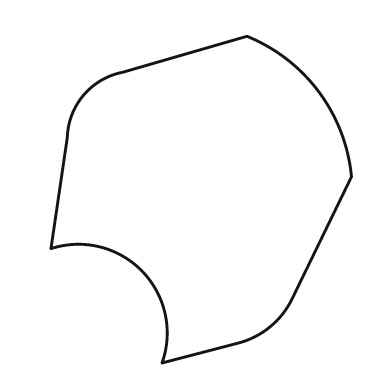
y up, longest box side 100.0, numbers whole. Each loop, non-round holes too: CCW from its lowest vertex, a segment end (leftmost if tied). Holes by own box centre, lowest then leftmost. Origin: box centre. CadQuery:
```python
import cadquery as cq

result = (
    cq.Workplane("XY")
    .moveTo(-12.0, -50.0)
    .lineTo(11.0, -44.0)
    .threePointArc((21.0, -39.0), (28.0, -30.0))
    .lineTo(46.0, 7.0)
    .threePointArc((36.0, 33.0), (14.0, 50.0))
    .lineTo(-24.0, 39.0)
    .threePointArc((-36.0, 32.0), (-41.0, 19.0))
    .lineTo(-46.0, -15.0)
    .threePointArc((-18.0, -22.0), (-12.0, -50.0))
    .close()
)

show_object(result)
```